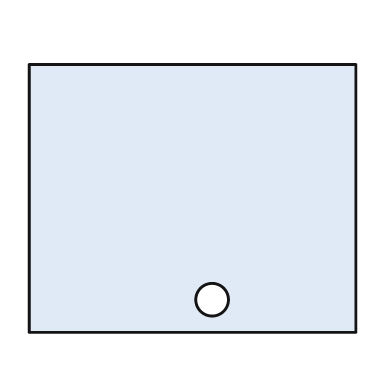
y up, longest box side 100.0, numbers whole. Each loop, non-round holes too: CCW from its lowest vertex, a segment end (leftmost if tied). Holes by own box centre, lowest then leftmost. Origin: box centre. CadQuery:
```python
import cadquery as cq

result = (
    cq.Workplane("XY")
    .moveTo(-50.0, -41.0)
    .lineTo(50.0, -41.0)
    .lineTo(50.0, 41.0)
    .lineTo(-50.0, 41.0)
    .close()
    .moveTo(6.0, -31.0)
    .circle(5.0)
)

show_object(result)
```